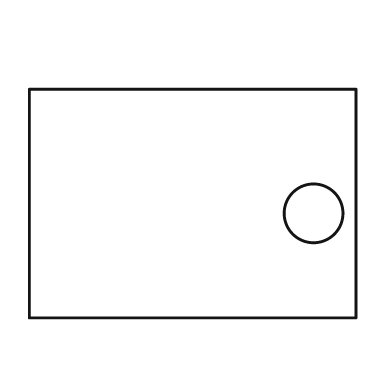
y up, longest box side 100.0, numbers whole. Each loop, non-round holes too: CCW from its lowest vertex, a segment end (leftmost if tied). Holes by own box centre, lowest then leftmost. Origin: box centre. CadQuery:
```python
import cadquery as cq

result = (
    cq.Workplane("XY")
    .moveTo(-50.0, -35.0)
    .lineTo(50.0, -35.0)
    .lineTo(50.0, 35.0)
    .lineTo(-50.0, 35.0)
    .close()
    .moveTo(37.0, -3.0)
    .circle(9.0)
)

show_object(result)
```